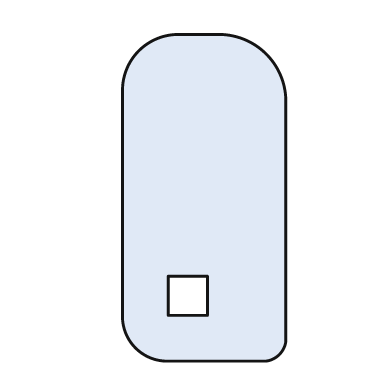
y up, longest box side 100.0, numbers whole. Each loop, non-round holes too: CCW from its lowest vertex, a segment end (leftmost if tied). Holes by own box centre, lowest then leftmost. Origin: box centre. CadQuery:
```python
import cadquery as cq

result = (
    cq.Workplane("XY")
    .moveTo(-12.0, -50.0)
    .lineTo(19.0, -50.0)
    .threePointArc((23.0, -48.0), (25.0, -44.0))
    .lineTo(25.0, 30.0)
    .threePointArc((19.0, 44.0), (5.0, 50.0))
    .lineTo(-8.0, 50.0)
    .threePointArc((-20.0, 45.0), (-25.0, 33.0))
    .lineTo(-25.0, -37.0)
    .threePointArc((-21.0, -46.0), (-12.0, -50.0))
    .close()
    .moveTo(-11.0, -36.0)
    .lineTo(1.0, -36.0)
    .lineTo(1.0, -24.0)
    .lineTo(-11.0, -24.0)
    .close()
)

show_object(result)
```